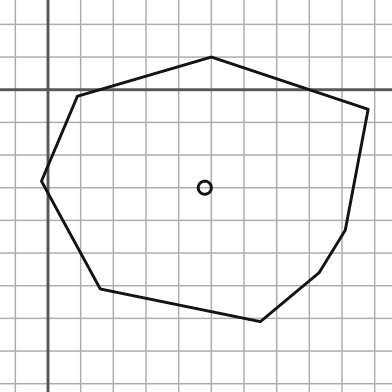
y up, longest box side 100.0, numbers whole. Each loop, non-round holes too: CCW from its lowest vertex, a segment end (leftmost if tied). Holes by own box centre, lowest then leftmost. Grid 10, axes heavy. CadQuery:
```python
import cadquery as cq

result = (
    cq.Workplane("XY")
    .moveTo(65.0, -71.0)
    .lineTo(83.0, -56.0)
    .lineTo(91.0, -43.0)
    .lineTo(98.0, -6.0)
    .lineTo(50.0, 10.0)
    .lineTo(9.0, -2.0)
    .lineTo(-2.0, -28.0)
    .lineTo(16.0, -61.0)
    .close()
    .moveTo(48.0, -30.0)
    .circle(2.0)
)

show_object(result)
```